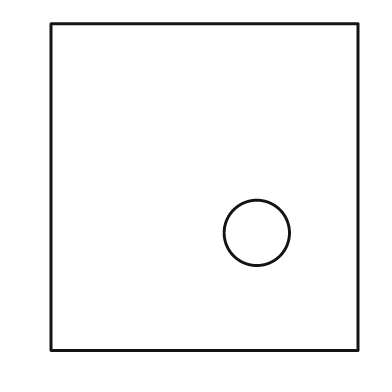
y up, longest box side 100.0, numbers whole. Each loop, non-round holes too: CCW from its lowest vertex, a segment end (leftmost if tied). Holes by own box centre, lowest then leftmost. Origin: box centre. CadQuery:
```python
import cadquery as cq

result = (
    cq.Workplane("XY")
    .moveTo(-47.0, -50.0)
    .lineTo(47.0, -50.0)
    .lineTo(47.0, 50.0)
    .lineTo(-47.0, 50.0)
    .close()
    .moveTo(16.0, -14.0)
    .circle(10.0)
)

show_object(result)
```